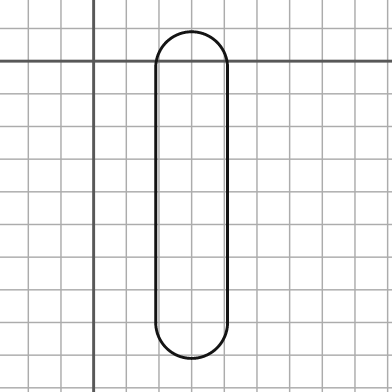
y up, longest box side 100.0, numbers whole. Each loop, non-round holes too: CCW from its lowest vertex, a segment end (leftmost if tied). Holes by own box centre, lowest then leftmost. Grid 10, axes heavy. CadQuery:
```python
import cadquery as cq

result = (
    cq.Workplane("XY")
    .moveTo(19.0, -80.0)
    .threePointArc((30.0, -91.0), (41.0, -80.0))
    .lineTo(41.0, -2.0)
    .threePointArc((30.0, 9.0), (19.0, -2.0))
    .close()
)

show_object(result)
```